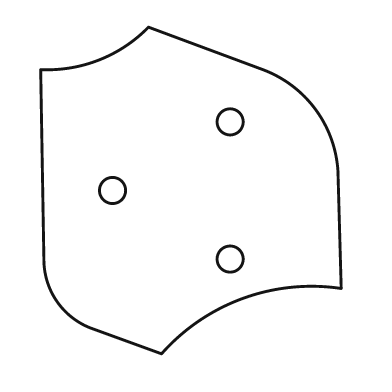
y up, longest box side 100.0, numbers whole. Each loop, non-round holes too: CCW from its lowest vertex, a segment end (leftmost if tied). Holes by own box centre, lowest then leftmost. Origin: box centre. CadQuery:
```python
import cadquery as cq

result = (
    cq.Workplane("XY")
    .moveTo(-9.0, -50.0)
    .threePointArc((16.0, -33.0), (46.0, -30.0))
    .lineTo(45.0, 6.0)
    .threePointArc((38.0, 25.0), (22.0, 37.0))
    .lineTo(-13.0, 50.0)
    .threePointArc((-28.0, 40.0), (-46.0, 37.0))
    .lineTo(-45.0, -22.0)
    .threePointArc((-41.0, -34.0), (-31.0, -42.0))
    .close()
    .moveTo(12.0, -21.0)
    .circle(4.0)
    .moveTo(-24.0, 0.0)
    .circle(4.0)
    .moveTo(12.0, 21.0)
    .circle(4.0)
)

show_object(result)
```